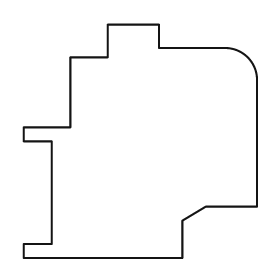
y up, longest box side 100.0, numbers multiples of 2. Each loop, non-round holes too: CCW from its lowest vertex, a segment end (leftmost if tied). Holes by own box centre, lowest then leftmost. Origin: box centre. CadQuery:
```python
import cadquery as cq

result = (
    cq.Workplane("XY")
    .moveTo(-50.0, -50.0)
    .lineTo(18.0, -50.0)
    .lineTo(18.0, -34.0)
    .lineTo(28.0, -28.0)
    .lineTo(50.0, -28.0)
    .lineTo(50.0, 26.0)
    .threePointArc((46.0, 36.0), (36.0, 40.0))
    .lineTo(8.0, 40.0)
    .lineTo(8.0, 50.0)
    .lineTo(-14.0, 50.0)
    .lineTo(-14.0, 36.0)
    .lineTo(-30.0, 36.0)
    .lineTo(-30.0, 6.0)
    .lineTo(-50.0, 6.0)
    .lineTo(-50.0, 0.0)
    .lineTo(-38.0, 0.0)
    .lineTo(-38.0, -44.0)
    .lineTo(-50.0, -44.0)
    .close()
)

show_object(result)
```